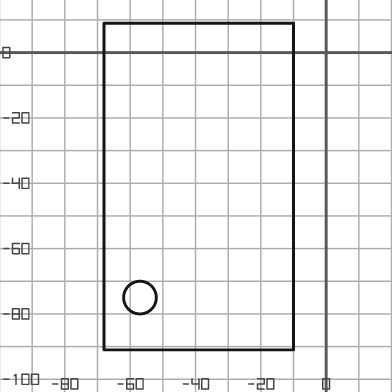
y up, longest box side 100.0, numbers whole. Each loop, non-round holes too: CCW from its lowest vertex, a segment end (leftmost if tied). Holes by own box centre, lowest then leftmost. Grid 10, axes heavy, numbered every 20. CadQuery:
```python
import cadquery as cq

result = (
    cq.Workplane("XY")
    .moveTo(-68.0, -91.0)
    .lineTo(-10.0, -91.0)
    .lineTo(-10.0, 9.0)
    .lineTo(-68.0, 9.0)
    .close()
    .moveTo(-57.0, -75.0)
    .circle(5.0)
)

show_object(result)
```